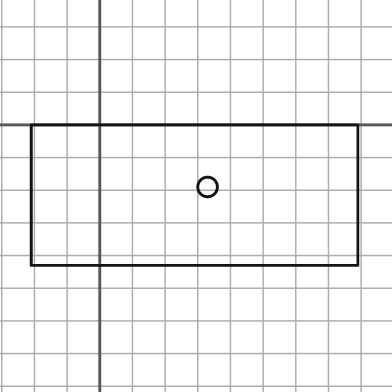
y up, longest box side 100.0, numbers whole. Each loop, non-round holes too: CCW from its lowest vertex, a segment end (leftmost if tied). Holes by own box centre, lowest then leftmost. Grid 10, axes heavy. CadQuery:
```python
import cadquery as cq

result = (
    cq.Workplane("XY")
    .moveTo(-21.0, -43.0)
    .lineTo(79.0, -43.0)
    .lineTo(79.0, 0.0)
    .lineTo(-21.0, 0.0)
    .close()
    .moveTo(33.0, -19.0)
    .circle(3.0)
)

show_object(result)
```